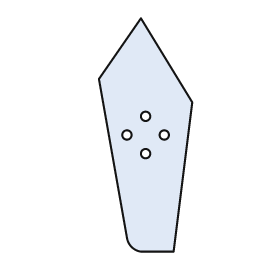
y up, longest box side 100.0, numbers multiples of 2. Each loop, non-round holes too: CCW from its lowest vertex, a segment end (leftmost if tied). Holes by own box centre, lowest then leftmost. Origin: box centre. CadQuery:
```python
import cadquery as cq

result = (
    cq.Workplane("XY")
    .moveTo(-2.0, -50.0)
    .lineTo(12.0, -50.0)
    .lineTo(20.0, 14.0)
    .lineTo(-2.0, 50.0)
    .lineTo(-20.0, 24.0)
    .lineTo(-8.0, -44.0)
    .threePointArc((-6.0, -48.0), (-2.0, -50.0))
    .close()
    .moveTo(0.0, -8.0)
    .circle(2.0)
    .moveTo(-8.0, 0.0)
    .circle(2.0)
    .moveTo(8.0, 0.0)
    .circle(2.0)
    .moveTo(0.0, 8.0)
    .circle(2.0)
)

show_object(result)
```